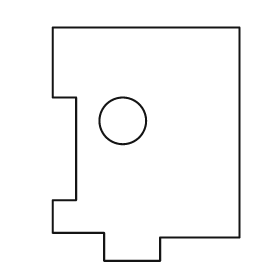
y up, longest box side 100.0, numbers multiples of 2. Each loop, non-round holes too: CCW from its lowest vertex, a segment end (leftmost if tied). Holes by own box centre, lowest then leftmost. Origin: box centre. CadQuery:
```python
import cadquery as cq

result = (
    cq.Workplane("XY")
    .moveTo(-18.0, -50.0)
    .lineTo(6.0, -50.0)
    .lineTo(6.0, -40.0)
    .lineTo(40.0, -40.0)
    .lineTo(40.0, 50.0)
    .lineTo(-40.0, 50.0)
    .lineTo(-40.0, 20.0)
    .lineTo(-30.0, 20.0)
    .lineTo(-30.0, -24.0)
    .lineTo(-40.0, -24.0)
    .lineTo(-40.0, -38.0)
    .lineTo(-18.0, -38.0)
    .close()
    .moveTo(-10.0, 10.0)
    .circle(10.0)
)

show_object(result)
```